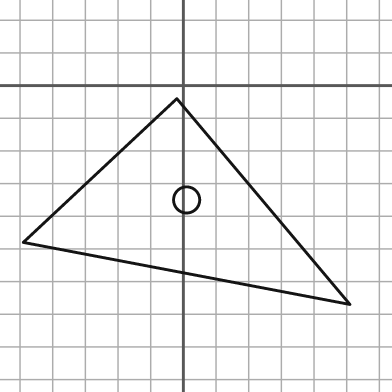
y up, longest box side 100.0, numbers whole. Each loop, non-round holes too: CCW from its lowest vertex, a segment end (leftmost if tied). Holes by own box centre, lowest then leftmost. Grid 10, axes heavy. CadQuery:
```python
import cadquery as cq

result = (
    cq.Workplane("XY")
    .moveTo(51.0, -67.0)
    .lineTo(-2.0, -4.0)
    .lineTo(-49.0, -48.0)
    .close()
    .moveTo(1.0, -35.0)
    .circle(4.0)
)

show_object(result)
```